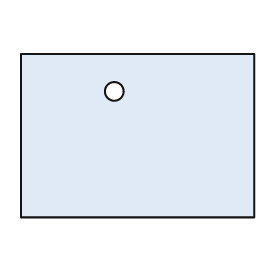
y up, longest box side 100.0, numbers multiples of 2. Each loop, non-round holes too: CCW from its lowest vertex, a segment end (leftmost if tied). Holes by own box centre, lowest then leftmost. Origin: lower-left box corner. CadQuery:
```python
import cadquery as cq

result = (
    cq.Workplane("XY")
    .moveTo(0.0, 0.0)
    .lineTo(100.0, 0.0)
    .lineTo(100.0, 70.0)
    .lineTo(0.0, 70.0)
    .close()
    .moveTo(40.0, 54.0)
    .circle(4.0)
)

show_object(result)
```